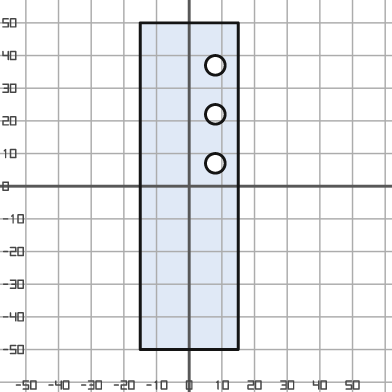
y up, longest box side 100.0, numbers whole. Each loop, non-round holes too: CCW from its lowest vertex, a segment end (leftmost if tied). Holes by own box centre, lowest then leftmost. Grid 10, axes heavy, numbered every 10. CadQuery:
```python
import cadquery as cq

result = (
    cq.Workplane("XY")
    .moveTo(-15.0, -50.0)
    .lineTo(15.0, -50.0)
    .lineTo(15.0, 50.0)
    .lineTo(-15.0, 50.0)
    .close()
    .moveTo(8.0, 7.0)
    .circle(3.0)
    .moveTo(8.0, 22.0)
    .circle(3.0)
    .moveTo(8.0, 37.0)
    .circle(3.0)
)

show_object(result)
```